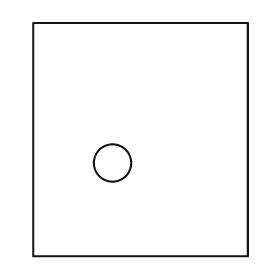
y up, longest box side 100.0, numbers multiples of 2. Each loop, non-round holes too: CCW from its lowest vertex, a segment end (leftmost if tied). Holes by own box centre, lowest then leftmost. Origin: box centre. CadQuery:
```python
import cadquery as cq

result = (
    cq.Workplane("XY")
    .moveTo(-46.0, -50.0)
    .lineTo(46.0, -50.0)
    .lineTo(46.0, 50.0)
    .lineTo(-46.0, 50.0)
    .close()
    .moveTo(-12.0, -10.0)
    .circle(8.0)
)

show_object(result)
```